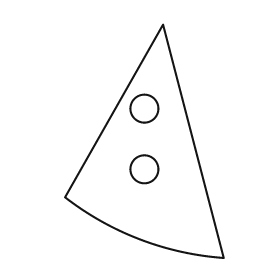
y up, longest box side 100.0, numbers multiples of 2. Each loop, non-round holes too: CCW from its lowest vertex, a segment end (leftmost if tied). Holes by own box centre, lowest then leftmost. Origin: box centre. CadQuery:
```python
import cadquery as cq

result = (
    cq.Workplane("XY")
    .moveTo(34.0, -50.0)
    .lineTo(8.0, 50.0)
    .lineTo(-34.0, -24.0)
    .threePointArc((-2.0, -42.0), (34.0, -50.0))
    .close()
    .moveTo(0.0, -12.0)
    .circle(6.0)
    .moveTo(0.0, 14.0)
    .circle(6.0)
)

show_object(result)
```